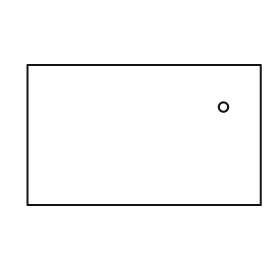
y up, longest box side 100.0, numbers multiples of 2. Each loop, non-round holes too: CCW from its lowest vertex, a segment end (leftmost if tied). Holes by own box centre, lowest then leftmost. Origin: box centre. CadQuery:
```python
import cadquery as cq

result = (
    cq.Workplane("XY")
    .moveTo(-50.0, -30.0)
    .lineTo(50.0, -30.0)
    .lineTo(50.0, 30.0)
    .lineTo(-50.0, 30.0)
    .close()
    .moveTo(34.0, 12.0)
    .circle(2.0)
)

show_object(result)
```